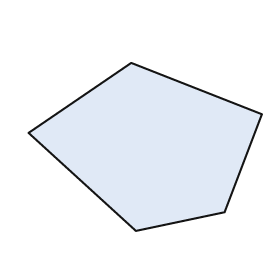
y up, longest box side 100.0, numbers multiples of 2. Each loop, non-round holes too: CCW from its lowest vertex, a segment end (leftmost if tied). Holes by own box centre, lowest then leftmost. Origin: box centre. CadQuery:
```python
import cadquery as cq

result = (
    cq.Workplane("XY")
    .moveTo(-4.0, -36.0)
    .lineTo(34.0, -28.0)
    .lineTo(50.0, 14.0)
    .lineTo(-6.0, 36.0)
    .lineTo(-50.0, 6.0)
    .close()
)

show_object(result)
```